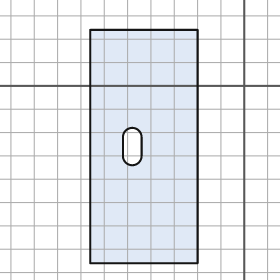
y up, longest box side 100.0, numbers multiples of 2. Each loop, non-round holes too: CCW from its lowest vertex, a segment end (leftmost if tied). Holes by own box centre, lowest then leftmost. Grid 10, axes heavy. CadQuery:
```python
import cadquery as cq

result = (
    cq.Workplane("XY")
    .moveTo(-66.0, -76.0)
    .lineTo(-20.0, -76.0)
    .lineTo(-20.0, 24.0)
    .lineTo(-66.0, 24.0)
    .close()
    .moveTo(-52.0, -30.0)
    .threePointArc((-48.0, -34.0), (-44.0, -30.0))
    .lineTo(-44.0, -22.0)
    .threePointArc((-48.0, -18.0), (-52.0, -22.0))
    .close()
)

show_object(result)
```